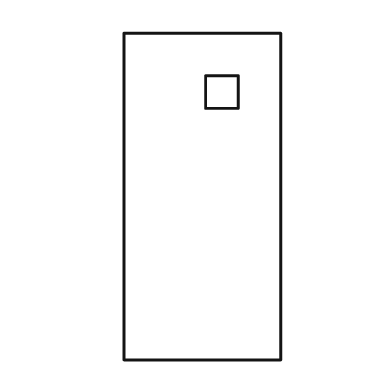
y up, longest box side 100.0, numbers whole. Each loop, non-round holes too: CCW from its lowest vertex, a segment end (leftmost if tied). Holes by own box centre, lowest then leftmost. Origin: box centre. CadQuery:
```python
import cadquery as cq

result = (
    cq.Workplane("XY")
    .moveTo(-24.0, -50.0)
    .lineTo(24.0, -50.0)
    .lineTo(24.0, 50.0)
    .lineTo(-24.0, 50.0)
    .close()
    .moveTo(1.0, 27.0)
    .lineTo(11.0, 27.0)
    .lineTo(11.0, 37.0)
    .lineTo(1.0, 37.0)
    .close()
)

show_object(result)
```